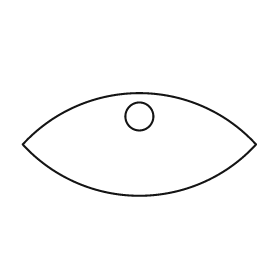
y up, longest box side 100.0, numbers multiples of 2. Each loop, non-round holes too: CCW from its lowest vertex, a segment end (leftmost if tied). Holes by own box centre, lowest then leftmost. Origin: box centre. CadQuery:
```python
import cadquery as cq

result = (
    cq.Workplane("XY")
    .moveTo(-50.0, 0.0)
    .threePointArc((0.0, -22.0), (50.0, 0.0))
    .threePointArc((0.0, 22.0), (-50.0, 0.0))
    .close()
    .moveTo(0.0, 12.0)
    .circle(6.0)
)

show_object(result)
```